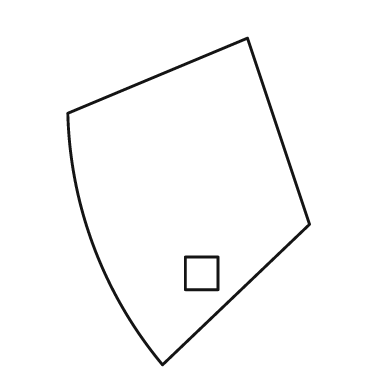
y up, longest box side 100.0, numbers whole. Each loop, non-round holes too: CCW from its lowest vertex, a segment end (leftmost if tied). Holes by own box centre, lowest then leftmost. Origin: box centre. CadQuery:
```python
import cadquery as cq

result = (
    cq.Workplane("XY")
    .moveTo(-8.0, -50.0)
    .lineTo(37.0, -7.0)
    .lineTo(18.0, 50.0)
    .lineTo(-37.0, 27.0)
    .threePointArc((-29.0, -14.0), (-8.0, -50.0))
    .close()
    .moveTo(-1.0, -27.0)
    .lineTo(9.0, -27.0)
    .lineTo(9.0, -17.0)
    .lineTo(-1.0, -17.0)
    .close()
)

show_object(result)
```